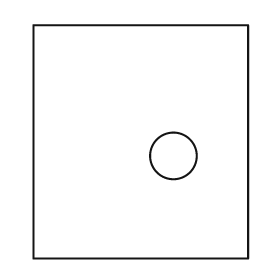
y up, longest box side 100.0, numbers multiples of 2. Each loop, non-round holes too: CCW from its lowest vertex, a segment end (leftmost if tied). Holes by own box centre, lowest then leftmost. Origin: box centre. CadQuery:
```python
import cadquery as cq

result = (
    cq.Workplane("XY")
    .moveTo(-46.0, -50.0)
    .lineTo(46.0, -50.0)
    .lineTo(46.0, 50.0)
    .lineTo(-46.0, 50.0)
    .close()
    .moveTo(14.0, -6.0)
    .circle(10.0)
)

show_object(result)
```